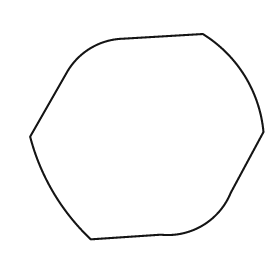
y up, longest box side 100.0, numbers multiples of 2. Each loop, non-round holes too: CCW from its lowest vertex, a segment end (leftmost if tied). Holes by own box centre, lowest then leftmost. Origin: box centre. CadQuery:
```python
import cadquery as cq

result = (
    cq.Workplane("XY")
    .moveTo(-24.0, -44.0)
    .lineTo(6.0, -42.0)
    .threePointArc((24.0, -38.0), (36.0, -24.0))
    .lineTo(50.0, 2.0)
    .threePointArc((42.0, 26.0), (24.0, 44.0))
    .lineTo(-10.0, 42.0)
    .threePointArc((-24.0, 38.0), (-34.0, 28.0))
    .lineTo(-50.0, 0.0)
    .threePointArc((-40.0, -24.0), (-24.0, -44.0))
    .close()
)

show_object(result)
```